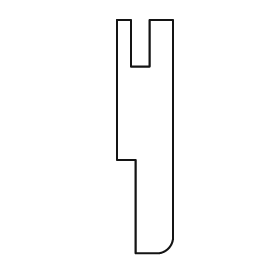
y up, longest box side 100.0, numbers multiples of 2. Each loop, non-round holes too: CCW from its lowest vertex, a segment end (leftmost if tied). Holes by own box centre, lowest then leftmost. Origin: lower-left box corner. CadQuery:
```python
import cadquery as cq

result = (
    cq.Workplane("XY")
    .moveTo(8.0, 0.0)
    .lineTo(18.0, 0.0)
    .threePointArc((22.0, 2.0), (24.0, 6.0))
    .lineTo(24.0, 100.0)
    .lineTo(14.0, 100.0)
    .lineTo(14.0, 80.0)
    .lineTo(6.0, 80.0)
    .lineTo(6.0, 100.0)
    .lineTo(0.0, 100.0)
    .lineTo(0.0, 40.0)
    .lineTo(8.0, 40.0)
    .close()
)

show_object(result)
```